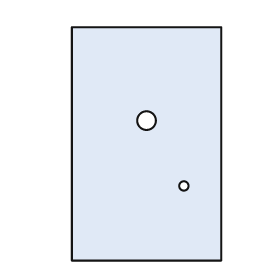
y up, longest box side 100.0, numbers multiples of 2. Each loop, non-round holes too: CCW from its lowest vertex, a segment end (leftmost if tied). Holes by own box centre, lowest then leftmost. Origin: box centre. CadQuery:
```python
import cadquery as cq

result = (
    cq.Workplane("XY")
    .moveTo(-32.0, -50.0)
    .lineTo(32.0, -50.0)
    .lineTo(32.0, 50.0)
    .lineTo(-32.0, 50.0)
    .close()
    .moveTo(16.0, -18.0)
    .circle(2.0)
    .moveTo(0.0, 10.0)
    .circle(4.0)
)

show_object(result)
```